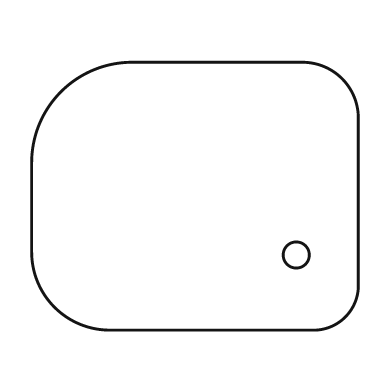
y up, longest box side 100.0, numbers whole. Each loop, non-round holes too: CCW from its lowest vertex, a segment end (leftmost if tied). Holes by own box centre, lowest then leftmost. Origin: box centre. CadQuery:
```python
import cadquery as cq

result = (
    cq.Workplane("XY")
    .moveTo(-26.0, -41.0)
    .lineTo(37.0, -41.0)
    .threePointArc((46.0, -37.0), (50.0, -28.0))
    .lineTo(50.0, 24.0)
    .threePointArc((45.0, 36.0), (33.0, 41.0))
    .lineTo(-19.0, 41.0)
    .threePointArc((-41.0, 32.0), (-50.0, 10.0))
    .lineTo(-50.0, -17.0)
    .threePointArc((-43.0, -34.0), (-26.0, -41.0))
    .close()
    .moveTo(31.0, -18.0)
    .circle(4.0)
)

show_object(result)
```